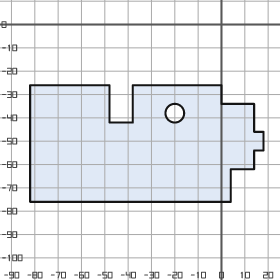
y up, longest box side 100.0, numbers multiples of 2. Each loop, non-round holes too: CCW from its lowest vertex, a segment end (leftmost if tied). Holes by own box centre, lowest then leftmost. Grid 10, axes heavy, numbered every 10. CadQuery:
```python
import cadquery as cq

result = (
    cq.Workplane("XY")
    .moveTo(-82.0, -76.0)
    .lineTo(4.0, -76.0)
    .lineTo(4.0, -62.0)
    .lineTo(14.0, -62.0)
    .lineTo(14.0, -54.0)
    .lineTo(18.0, -54.0)
    .lineTo(18.0, -46.0)
    .lineTo(14.0, -46.0)
    .lineTo(14.0, -34.0)
    .lineTo(0.0, -34.0)
    .lineTo(0.0, -26.0)
    .lineTo(-38.0, -26.0)
    .lineTo(-38.0, -42.0)
    .lineTo(-48.0, -42.0)
    .lineTo(-48.0, -26.0)
    .lineTo(-82.0, -26.0)
    .close()
    .moveTo(-20.0, -38.0)
    .circle(4.0)
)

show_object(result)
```